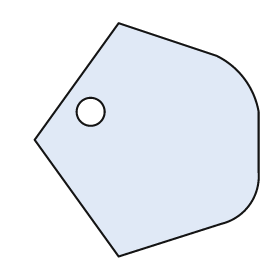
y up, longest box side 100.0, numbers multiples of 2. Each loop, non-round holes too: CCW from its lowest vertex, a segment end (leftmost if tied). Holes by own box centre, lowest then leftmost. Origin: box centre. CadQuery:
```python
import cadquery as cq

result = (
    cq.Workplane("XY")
    .moveTo(-12.0, -50.0)
    .lineTo(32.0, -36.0)
    .threePointArc((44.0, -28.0), (48.0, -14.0))
    .lineTo(48.0, 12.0)
    .threePointArc((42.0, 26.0), (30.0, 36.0))
    .lineTo(-12.0, 50.0)
    .lineTo(-48.0, 0.0)
    .close()
    .moveTo(-24.0, 12.0)
    .circle(6.0)
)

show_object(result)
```